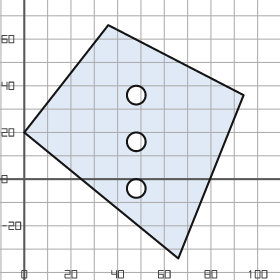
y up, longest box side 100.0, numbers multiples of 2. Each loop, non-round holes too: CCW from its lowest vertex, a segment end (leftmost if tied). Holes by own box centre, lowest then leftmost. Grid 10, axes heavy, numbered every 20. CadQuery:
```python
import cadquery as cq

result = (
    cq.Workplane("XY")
    .moveTo(66.0, -34.0)
    .lineTo(94.0, 36.0)
    .lineTo(36.0, 66.0)
    .lineTo(0.0, 20.0)
    .close()
    .moveTo(48.0, -4.0)
    .circle(4.0)
    .moveTo(48.0, 16.0)
    .circle(4.0)
    .moveTo(48.0, 36.0)
    .circle(4.0)
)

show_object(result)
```